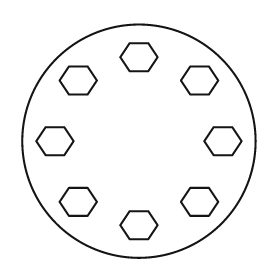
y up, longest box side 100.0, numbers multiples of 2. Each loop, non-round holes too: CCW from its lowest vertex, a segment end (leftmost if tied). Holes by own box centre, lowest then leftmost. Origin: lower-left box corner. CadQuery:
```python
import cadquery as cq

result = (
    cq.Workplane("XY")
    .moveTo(50.0, 50.0)
    .circle(50.0)
    .moveTo(46.0, 8.0)
    .lineTo(54.0, 8.0)
    .lineTo(58.0, 14.0)
    .lineTo(54.0, 20.0)
    .lineTo(46.0, 20.0)
    .lineTo(42.0, 14.0)
    .close()
    .moveTo(20.0, 18.0)
    .lineTo(28.0, 18.0)
    .lineTo(32.0, 24.0)
    .lineTo(28.0, 30.0)
    .lineTo(20.0, 30.0)
    .lineTo(16.0, 24.0)
    .close()
    .moveTo(72.0, 18.0)
    .lineTo(80.0, 18.0)
    .lineTo(84.0, 24.0)
    .lineTo(80.0, 30.0)
    .lineTo(72.0, 30.0)
    .lineTo(68.0, 24.0)
    .close()
    .moveTo(10.0, 44.0)
    .lineTo(18.0, 44.0)
    .lineTo(22.0, 50.0)
    .lineTo(18.0, 56.0)
    .lineTo(10.0, 56.0)
    .lineTo(6.0, 50.0)
    .close()
    .moveTo(82.0, 44.0)
    .lineTo(90.0, 44.0)
    .lineTo(94.0, 50.0)
    .lineTo(90.0, 56.0)
    .lineTo(82.0, 56.0)
    .lineTo(78.0, 50.0)
    .close()
    .moveTo(20.0, 70.0)
    .lineTo(28.0, 70.0)
    .lineTo(32.0, 76.0)
    .lineTo(28.0, 82.0)
    .lineTo(20.0, 82.0)
    .lineTo(16.0, 76.0)
    .close()
    .moveTo(72.0, 70.0)
    .lineTo(80.0, 70.0)
    .lineTo(84.0, 76.0)
    .lineTo(80.0, 82.0)
    .lineTo(72.0, 82.0)
    .lineTo(68.0, 76.0)
    .close()
    .moveTo(46.0, 80.0)
    .lineTo(54.0, 80.0)
    .lineTo(58.0, 86.0)
    .lineTo(54.0, 92.0)
    .lineTo(46.0, 92.0)
    .lineTo(42.0, 86.0)
    .close()
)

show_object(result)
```